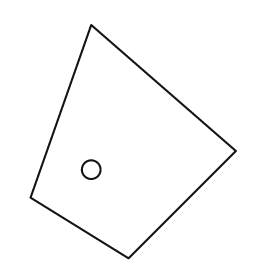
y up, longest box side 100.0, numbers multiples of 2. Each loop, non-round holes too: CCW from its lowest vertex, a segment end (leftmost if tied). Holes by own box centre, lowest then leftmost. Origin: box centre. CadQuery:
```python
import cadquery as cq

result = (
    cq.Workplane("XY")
    .moveTo(-2.0, -50.0)
    .lineTo(44.0, -4.0)
    .lineTo(-18.0, 50.0)
    .lineTo(-44.0, -24.0)
    .close()
    .moveTo(-18.0, -12.0)
    .circle(4.0)
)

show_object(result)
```